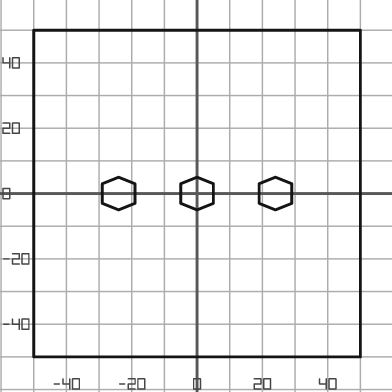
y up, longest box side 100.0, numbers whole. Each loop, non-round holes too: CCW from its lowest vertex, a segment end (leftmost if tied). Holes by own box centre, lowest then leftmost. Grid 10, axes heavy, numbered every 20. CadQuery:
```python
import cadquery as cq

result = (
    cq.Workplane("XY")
    .moveTo(-50.0, -50.0)
    .lineTo(50.0, -50.0)
    .lineTo(50.0, 50.0)
    .lineTo(-50.0, 50.0)
    .close()
    .moveTo(-24.0, -5.0)
    .lineTo(-19.0, -3.0)
    .lineTo(-19.0, 3.0)
    .lineTo(-24.0, 5.0)
    .lineTo(-29.0, 3.0)
    .lineTo(-29.0, -3.0)
    .close()
    .moveTo(0.0, -5.0)
    .lineTo(5.0, -3.0)
    .lineTo(5.0, 3.0)
    .lineTo(0.0, 5.0)
    .lineTo(-5.0, 3.0)
    .lineTo(-5.0, -3.0)
    .close()
    .moveTo(24.0, -5.0)
    .lineTo(29.0, -3.0)
    .lineTo(29.0, 3.0)
    .lineTo(24.0, 5.0)
    .lineTo(19.0, 3.0)
    .lineTo(19.0, -3.0)
    .close()
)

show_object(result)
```